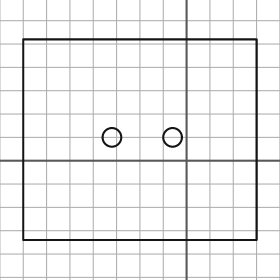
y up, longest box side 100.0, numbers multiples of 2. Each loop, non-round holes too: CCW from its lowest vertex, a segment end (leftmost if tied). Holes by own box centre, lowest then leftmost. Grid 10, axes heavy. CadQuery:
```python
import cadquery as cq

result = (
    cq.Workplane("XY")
    .moveTo(-70.0, -34.0)
    .lineTo(30.0, -34.0)
    .lineTo(30.0, 52.0)
    .lineTo(-70.0, 52.0)
    .close()
    .moveTo(-32.0, 10.0)
    .circle(4.0)
    .moveTo(-6.0, 10.0)
    .circle(4.0)
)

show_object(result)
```